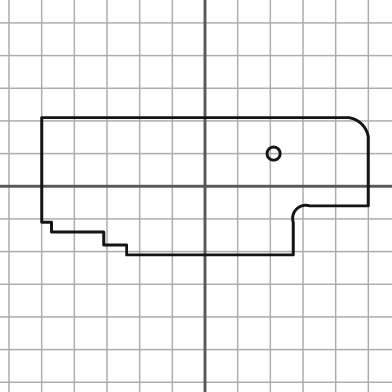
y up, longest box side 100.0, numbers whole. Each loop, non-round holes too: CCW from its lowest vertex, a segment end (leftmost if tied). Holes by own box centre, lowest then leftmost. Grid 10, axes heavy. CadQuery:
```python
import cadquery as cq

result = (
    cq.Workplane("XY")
    .moveTo(-24.0, -21.0)
    .lineTo(27.0, -21.0)
    .lineTo(27.0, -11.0)
    .threePointArc((28.0, -7.0), (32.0, -6.0))
    .lineTo(50.0, -6.0)
    .lineTo(50.0, 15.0)
    .threePointArc((48.0, 19.0), (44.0, 21.0))
    .lineTo(-50.0, 21.0)
    .lineTo(-50.0, -11.0)
    .lineTo(-47.0, -11.0)
    .lineTo(-47.0, -14.0)
    .lineTo(-31.0, -14.0)
    .lineTo(-31.0, -18.0)
    .lineTo(-24.0, -18.0)
    .close()
    .moveTo(21.0, 10.0)
    .circle(2.0)
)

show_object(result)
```